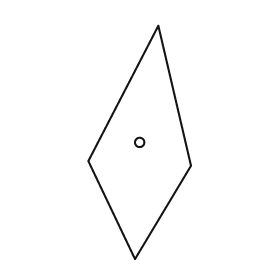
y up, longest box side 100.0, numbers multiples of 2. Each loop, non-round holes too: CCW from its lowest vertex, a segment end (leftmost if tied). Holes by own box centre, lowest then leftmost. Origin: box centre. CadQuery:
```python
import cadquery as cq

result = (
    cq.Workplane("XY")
    .moveTo(-2.0, -50.0)
    .lineTo(22.0, -10.0)
    .lineTo(8.0, 50.0)
    .lineTo(-22.0, -8.0)
    .close()
    .moveTo(0.0, 0.0)
    .circle(2.0)
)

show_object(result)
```